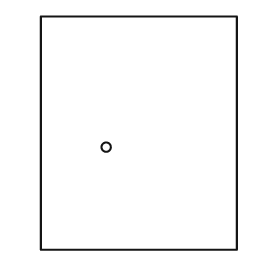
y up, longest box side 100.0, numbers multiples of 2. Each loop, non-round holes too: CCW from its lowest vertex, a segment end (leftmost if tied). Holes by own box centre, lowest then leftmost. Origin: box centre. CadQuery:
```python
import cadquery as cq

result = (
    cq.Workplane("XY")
    .moveTo(-42.0, -50.0)
    .lineTo(42.0, -50.0)
    .lineTo(42.0, 50.0)
    .lineTo(-42.0, 50.0)
    .close()
    .moveTo(-14.0, -6.0)
    .circle(2.0)
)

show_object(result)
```